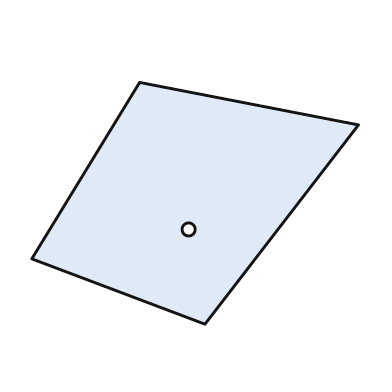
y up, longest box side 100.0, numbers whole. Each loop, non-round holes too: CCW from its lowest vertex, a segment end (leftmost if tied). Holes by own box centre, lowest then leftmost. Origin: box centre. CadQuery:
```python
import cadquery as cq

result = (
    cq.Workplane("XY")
    .moveTo(3.0, -37.0)
    .lineTo(50.0, 24.0)
    .lineTo(-17.0, 37.0)
    .lineTo(-50.0, -17.0)
    .close()
    .moveTo(-2.0, -8.0)
    .circle(2.0)
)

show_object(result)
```